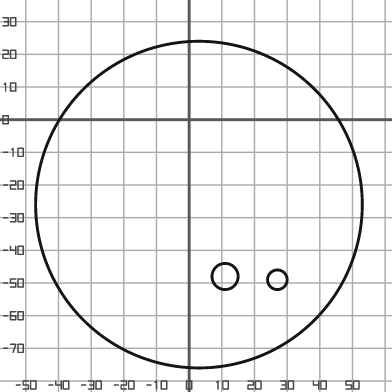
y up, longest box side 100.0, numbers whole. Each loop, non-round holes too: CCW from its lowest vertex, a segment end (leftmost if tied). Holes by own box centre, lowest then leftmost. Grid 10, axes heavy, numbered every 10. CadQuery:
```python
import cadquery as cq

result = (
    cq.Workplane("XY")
    .moveTo(3.0, -26.0)
    .circle(50.0)
    .moveTo(27.0, -49.0)
    .circle(3.0)
    .moveTo(11.0, -48.0)
    .circle(4.0)
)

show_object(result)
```